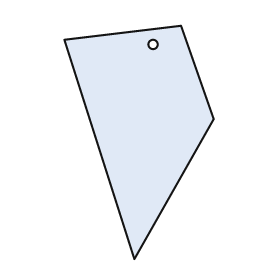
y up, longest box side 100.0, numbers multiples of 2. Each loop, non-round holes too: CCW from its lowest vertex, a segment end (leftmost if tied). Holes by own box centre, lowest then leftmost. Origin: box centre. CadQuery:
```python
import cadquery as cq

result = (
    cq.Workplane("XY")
    .moveTo(-2.0, -50.0)
    .lineTo(32.0, 10.0)
    .lineTo(18.0, 50.0)
    .lineTo(-32.0, 44.0)
    .close()
    .moveTo(6.0, 42.0)
    .circle(2.0)
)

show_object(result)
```